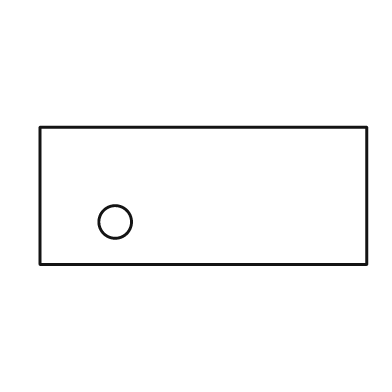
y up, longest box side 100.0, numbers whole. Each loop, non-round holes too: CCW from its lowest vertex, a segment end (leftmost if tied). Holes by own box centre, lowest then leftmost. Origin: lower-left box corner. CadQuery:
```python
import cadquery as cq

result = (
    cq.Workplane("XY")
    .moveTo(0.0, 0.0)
    .lineTo(100.0, 0.0)
    .lineTo(100.0, 42.0)
    .lineTo(0.0, 42.0)
    .close()
    .moveTo(23.0, 13.0)
    .circle(5.0)
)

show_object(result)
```